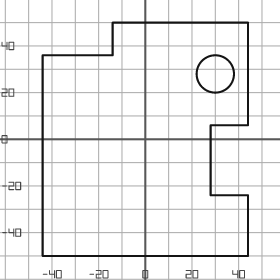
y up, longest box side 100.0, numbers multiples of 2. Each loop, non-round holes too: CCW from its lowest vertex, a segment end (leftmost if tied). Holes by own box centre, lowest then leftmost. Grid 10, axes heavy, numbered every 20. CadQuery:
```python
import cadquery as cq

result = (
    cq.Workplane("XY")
    .moveTo(-44.0, -50.0)
    .lineTo(44.0, -50.0)
    .lineTo(44.0, -24.0)
    .lineTo(28.0, -24.0)
    .lineTo(28.0, 6.0)
    .lineTo(44.0, 6.0)
    .lineTo(44.0, 50.0)
    .lineTo(-14.0, 50.0)
    .lineTo(-14.0, 36.0)
    .lineTo(-44.0, 36.0)
    .close()
    .moveTo(30.0, 28.0)
    .circle(8.0)
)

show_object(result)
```